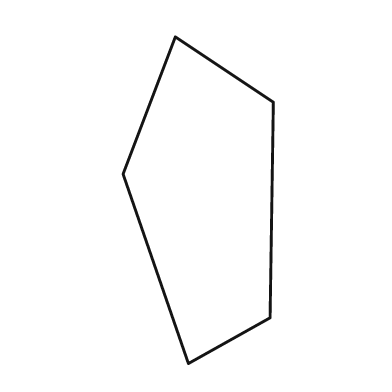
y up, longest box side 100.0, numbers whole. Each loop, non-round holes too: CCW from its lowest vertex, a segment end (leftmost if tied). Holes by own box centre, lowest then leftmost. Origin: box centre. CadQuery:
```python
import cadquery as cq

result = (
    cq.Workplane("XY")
    .moveTo(-3.0, -50.0)
    .lineTo(22.0, -36.0)
    .lineTo(23.0, 30.0)
    .lineTo(-7.0, 50.0)
    .lineTo(-23.0, 8.0)
    .close()
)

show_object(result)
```